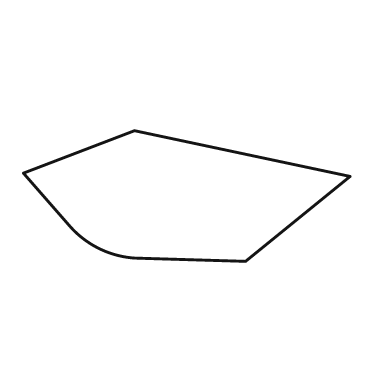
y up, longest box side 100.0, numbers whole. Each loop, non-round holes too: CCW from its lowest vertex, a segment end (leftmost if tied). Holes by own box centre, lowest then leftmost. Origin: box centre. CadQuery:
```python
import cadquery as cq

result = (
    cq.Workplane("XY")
    .moveTo(18.0, -20.0)
    .lineTo(50.0, 6.0)
    .lineTo(-16.0, 20.0)
    .lineTo(-50.0, 7.0)
    .lineTo(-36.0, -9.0)
    .threePointArc((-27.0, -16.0), (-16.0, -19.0))
    .close()
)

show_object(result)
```